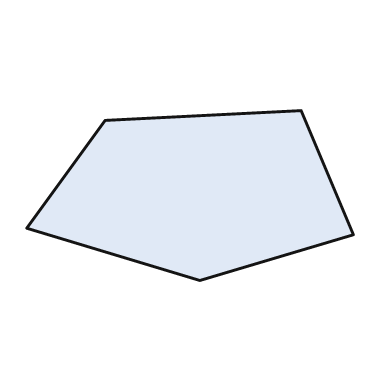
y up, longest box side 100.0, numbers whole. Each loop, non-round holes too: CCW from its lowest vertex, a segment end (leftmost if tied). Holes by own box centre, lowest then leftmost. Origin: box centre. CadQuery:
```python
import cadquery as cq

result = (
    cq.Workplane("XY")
    .moveTo(3.0, -26.0)
    .lineTo(50.0, -12.0)
    .lineTo(34.0, 26.0)
    .lineTo(-26.0, 23.0)
    .lineTo(-50.0, -10.0)
    .close()
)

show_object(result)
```